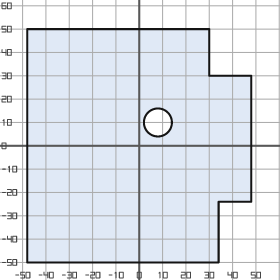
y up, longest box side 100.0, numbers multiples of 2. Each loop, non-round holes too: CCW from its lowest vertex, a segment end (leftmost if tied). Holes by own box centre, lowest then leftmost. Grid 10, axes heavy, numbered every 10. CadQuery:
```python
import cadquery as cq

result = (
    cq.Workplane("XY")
    .moveTo(-48.0, -50.0)
    .lineTo(34.0, -50.0)
    .lineTo(34.0, -24.0)
    .lineTo(48.0, -24.0)
    .lineTo(48.0, 30.0)
    .lineTo(30.0, 30.0)
    .lineTo(30.0, 50.0)
    .lineTo(-48.0, 50.0)
    .close()
    .moveTo(8.0, 10.0)
    .circle(6.0)
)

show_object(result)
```